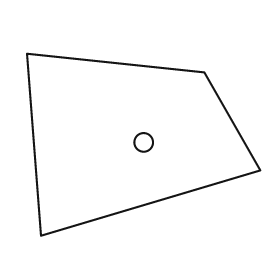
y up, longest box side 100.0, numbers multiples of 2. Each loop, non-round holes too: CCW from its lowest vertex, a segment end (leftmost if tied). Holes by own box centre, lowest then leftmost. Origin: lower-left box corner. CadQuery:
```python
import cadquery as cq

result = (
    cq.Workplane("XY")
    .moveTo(6.0, 0.0)
    .lineTo(100.0, 28.0)
    .lineTo(76.0, 70.0)
    .lineTo(0.0, 78.0)
    .close()
    .moveTo(50.0, 40.0)
    .circle(4.0)
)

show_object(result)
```